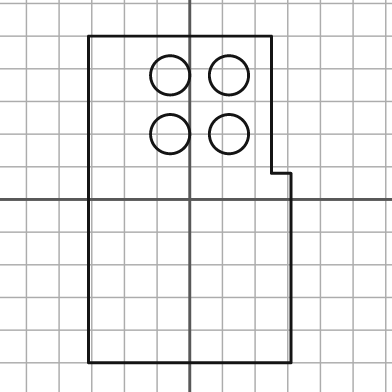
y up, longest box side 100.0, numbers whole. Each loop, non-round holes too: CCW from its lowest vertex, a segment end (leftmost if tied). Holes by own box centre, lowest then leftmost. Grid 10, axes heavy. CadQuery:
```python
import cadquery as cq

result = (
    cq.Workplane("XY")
    .moveTo(-31.0, -50.0)
    .lineTo(31.0, -50.0)
    .lineTo(31.0, 8.0)
    .lineTo(25.0, 8.0)
    .lineTo(25.0, 50.0)
    .lineTo(-31.0, 50.0)
    .close()
    .moveTo(-6.0, 20.0)
    .circle(6.0)
    .moveTo(12.0, 20.0)
    .circle(6.0)
    .moveTo(-6.0, 38.0)
    .circle(6.0)
    .moveTo(12.0, 38.0)
    .circle(6.0)
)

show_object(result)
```